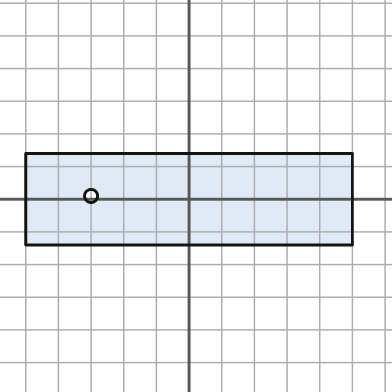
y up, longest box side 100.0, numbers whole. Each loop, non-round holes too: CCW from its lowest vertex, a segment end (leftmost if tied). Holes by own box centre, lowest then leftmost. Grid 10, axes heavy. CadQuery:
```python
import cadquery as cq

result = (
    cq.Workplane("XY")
    .moveTo(-50.0, -14.0)
    .lineTo(50.0, -14.0)
    .lineTo(50.0, 14.0)
    .lineTo(-50.0, 14.0)
    .close()
    .moveTo(-30.0, 1.0)
    .circle(2.0)
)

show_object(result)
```